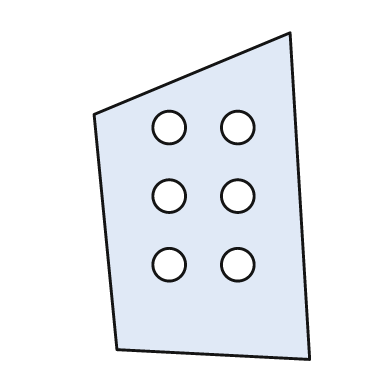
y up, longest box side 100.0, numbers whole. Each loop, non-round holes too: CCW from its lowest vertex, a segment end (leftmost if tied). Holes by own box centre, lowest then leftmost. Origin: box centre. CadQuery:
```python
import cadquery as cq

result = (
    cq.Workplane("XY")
    .moveTo(33.0, -50.0)
    .lineTo(27.0, 50.0)
    .lineTo(-33.0, 25.0)
    .lineTo(-26.0, -47.0)
    .close()
    .moveTo(-10.0, -21.0)
    .circle(5.0)
    .moveTo(11.0, -21.0)
    .circle(5.0)
    .moveTo(-10.0, 0.0)
    .circle(5.0)
    .moveTo(11.0, 0.0)
    .circle(5.0)
    .moveTo(-10.0, 21.0)
    .circle(5.0)
    .moveTo(11.0, 21.0)
    .circle(5.0)
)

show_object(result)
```